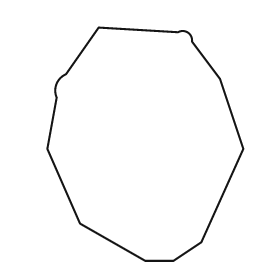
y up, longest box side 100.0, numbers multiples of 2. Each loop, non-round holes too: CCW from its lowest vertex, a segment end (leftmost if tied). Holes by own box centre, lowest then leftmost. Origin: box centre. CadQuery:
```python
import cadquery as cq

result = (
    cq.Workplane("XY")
    .moveTo(0.0, -50.0)
    .lineTo(12.0, -50.0)
    .lineTo(24.0, -42.0)
    .lineTo(42.0, -2.0)
    .lineTo(32.0, 28.0)
    .lineTo(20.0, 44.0)
    .threePointArc((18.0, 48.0), (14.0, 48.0))
    .lineTo(-20.0, 50.0)
    .lineTo(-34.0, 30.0)
    .threePointArc((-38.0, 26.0), (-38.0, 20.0))
    .lineTo(-42.0, -2.0)
    .lineTo(-28.0, -34.0)
    .close()
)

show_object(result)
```